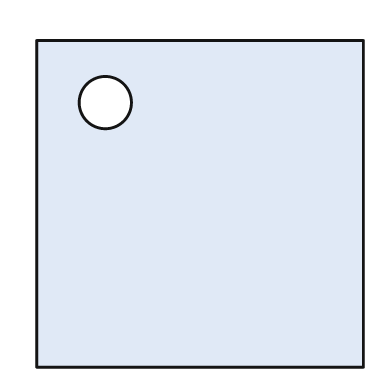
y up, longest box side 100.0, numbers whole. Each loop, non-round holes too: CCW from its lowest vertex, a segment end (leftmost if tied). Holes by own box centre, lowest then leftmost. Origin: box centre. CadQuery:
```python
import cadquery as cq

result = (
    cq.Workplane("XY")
    .moveTo(-50.0, -50.0)
    .lineTo(50.0, -50.0)
    .lineTo(50.0, 50.0)
    .lineTo(-50.0, 50.0)
    .close()
    .moveTo(-29.0, 31.0)
    .circle(8.0)
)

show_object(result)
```